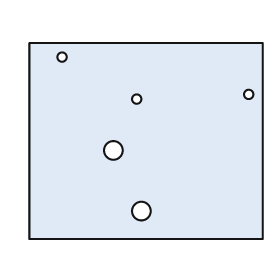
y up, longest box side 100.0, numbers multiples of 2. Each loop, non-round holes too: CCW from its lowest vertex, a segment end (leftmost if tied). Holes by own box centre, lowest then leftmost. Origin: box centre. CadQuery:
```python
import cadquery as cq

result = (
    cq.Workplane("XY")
    .moveTo(-50.0, -42.0)
    .lineTo(50.0, -42.0)
    .lineTo(50.0, 42.0)
    .lineTo(-50.0, 42.0)
    .close()
    .moveTo(-2.0, -30.0)
    .circle(4.0)
    .moveTo(-14.0, -4.0)
    .circle(4.0)
    .moveTo(-4.0, 18.0)
    .circle(2.0)
    .moveTo(44.0, 20.0)
    .circle(2.0)
    .moveTo(-36.0, 36.0)
    .circle(2.0)
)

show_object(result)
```